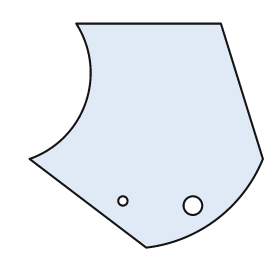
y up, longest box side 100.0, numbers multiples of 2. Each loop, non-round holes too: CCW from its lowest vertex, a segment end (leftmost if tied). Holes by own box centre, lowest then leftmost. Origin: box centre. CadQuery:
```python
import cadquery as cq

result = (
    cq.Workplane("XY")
    .moveTo(0.0, -48.0)
    .threePointArc((30.0, -36.0), (50.0, -10.0))
    .lineTo(32.0, 48.0)
    .lineTo(-30.0, 48.0)
    .threePointArc((-26.0, 14.0), (-50.0, -10.0))
    .close()
    .moveTo(20.0, -30.0)
    .circle(4.0)
    .moveTo(-10.0, -28.0)
    .circle(2.0)
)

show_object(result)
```